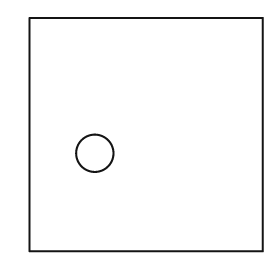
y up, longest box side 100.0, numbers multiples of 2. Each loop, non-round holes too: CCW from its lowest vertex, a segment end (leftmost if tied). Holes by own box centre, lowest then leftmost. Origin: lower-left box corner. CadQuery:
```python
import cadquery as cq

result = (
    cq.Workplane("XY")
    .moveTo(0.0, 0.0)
    .lineTo(100.0, 0.0)
    .lineTo(100.0, 100.0)
    .lineTo(0.0, 100.0)
    .close()
    .moveTo(28.0, 42.0)
    .circle(8.0)
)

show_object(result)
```